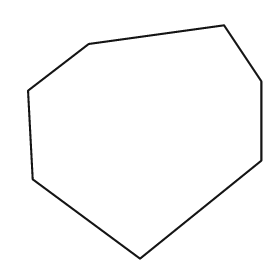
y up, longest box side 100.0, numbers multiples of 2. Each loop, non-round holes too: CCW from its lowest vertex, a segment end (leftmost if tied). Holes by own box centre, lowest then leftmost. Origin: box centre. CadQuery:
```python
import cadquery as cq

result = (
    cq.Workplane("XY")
    .moveTo(-2.0, -50.0)
    .lineTo(50.0, -8.0)
    .lineTo(50.0, 26.0)
    .lineTo(34.0, 50.0)
    .lineTo(-24.0, 42.0)
    .lineTo(-50.0, 22.0)
    .lineTo(-48.0, -16.0)
    .close()
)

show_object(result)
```